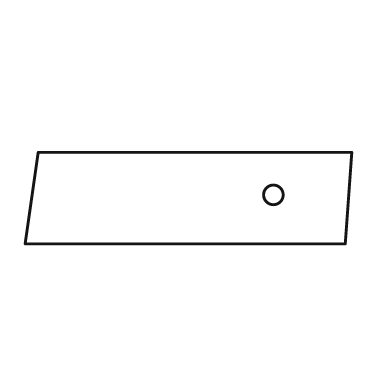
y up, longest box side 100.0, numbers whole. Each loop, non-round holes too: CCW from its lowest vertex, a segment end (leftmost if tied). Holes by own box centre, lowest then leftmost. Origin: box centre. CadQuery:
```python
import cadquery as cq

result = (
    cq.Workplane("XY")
    .moveTo(-50.0, -14.0)
    .lineTo(48.0, -14.0)
    .lineTo(50.0, 14.0)
    .lineTo(-46.0, 14.0)
    .close()
    .moveTo(26.0, 1.0)
    .circle(3.0)
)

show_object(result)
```